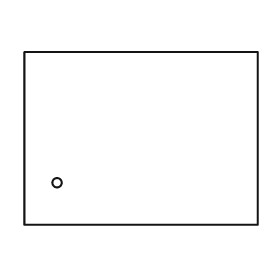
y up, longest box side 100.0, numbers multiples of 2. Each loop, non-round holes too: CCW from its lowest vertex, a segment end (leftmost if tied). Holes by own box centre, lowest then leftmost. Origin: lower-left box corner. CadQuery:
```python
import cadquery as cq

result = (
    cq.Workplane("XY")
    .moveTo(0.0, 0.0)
    .lineTo(100.0, 0.0)
    .lineTo(100.0, 74.0)
    .lineTo(0.0, 74.0)
    .close()
    .moveTo(14.0, 18.0)
    .circle(2.0)
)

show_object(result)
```